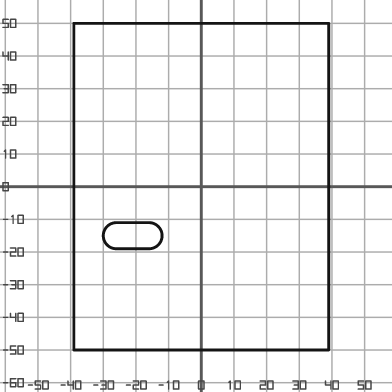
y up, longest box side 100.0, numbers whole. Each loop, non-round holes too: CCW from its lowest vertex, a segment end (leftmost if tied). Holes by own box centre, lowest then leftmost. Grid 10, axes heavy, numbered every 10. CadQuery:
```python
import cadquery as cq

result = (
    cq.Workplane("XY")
    .moveTo(-39.0, -50.0)
    .lineTo(39.0, -50.0)
    .lineTo(39.0, 50.0)
    .lineTo(-39.0, 50.0)
    .close()
    .moveTo(-26.0, -19.0)
    .lineTo(-16.0, -19.0)
    .threePointArc((-12.0, -15.0), (-16.0, -11.0))
    .lineTo(-26.0, -11.0)
    .threePointArc((-30.0, -15.0), (-26.0, -19.0))
    .close()
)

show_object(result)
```